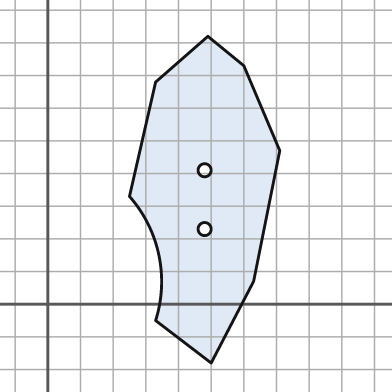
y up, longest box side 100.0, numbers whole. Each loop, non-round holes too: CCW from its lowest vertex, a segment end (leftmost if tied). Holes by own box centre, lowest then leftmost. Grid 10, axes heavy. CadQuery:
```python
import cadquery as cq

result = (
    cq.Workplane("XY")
    .moveTo(50.0, -18.0)
    .lineTo(63.0, 7.0)
    .lineTo(71.0, 47.0)
    .lineTo(60.0, 73.0)
    .lineTo(49.0, 82.0)
    .lineTo(33.0, 68.0)
    .lineTo(25.0, 33.0)
    .threePointArc((34.0, 15.0), (33.0, -5.0))
    .close()
    .moveTo(48.0, 23.0)
    .circle(2.0)
    .moveTo(48.0, 41.0)
    .circle(2.0)
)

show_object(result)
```